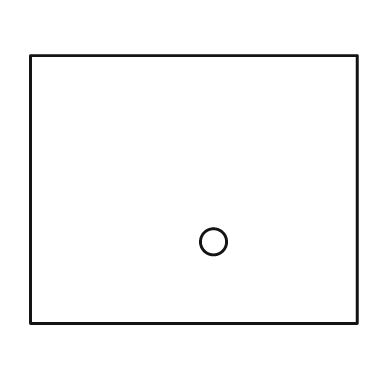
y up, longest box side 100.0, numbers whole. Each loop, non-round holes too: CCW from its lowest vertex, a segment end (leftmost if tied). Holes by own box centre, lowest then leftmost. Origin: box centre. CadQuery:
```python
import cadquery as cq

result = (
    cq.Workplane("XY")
    .moveTo(-50.0, -41.0)
    .lineTo(50.0, -41.0)
    .lineTo(50.0, 41.0)
    .lineTo(-50.0, 41.0)
    .close()
    .moveTo(6.0, -16.0)
    .circle(4.0)
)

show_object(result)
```